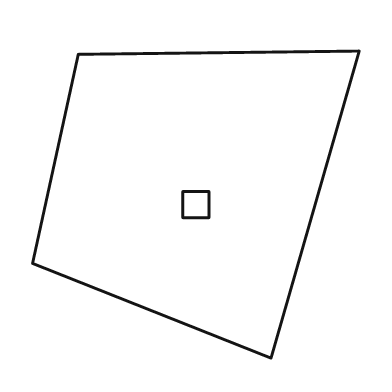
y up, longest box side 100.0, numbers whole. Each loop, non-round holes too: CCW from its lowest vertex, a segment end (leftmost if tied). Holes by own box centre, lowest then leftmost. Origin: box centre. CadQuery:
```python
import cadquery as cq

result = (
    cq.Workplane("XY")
    .moveTo(23.0, -47.0)
    .lineTo(50.0, 47.0)
    .lineTo(-36.0, 46.0)
    .lineTo(-50.0, -18.0)
    .close()
    .moveTo(-4.0, -4.0)
    .lineTo(4.0, -4.0)
    .lineTo(4.0, 4.0)
    .lineTo(-4.0, 4.0)
    .close()
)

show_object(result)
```